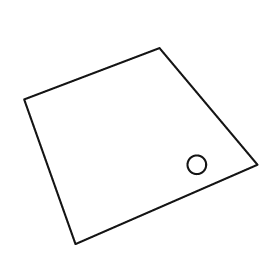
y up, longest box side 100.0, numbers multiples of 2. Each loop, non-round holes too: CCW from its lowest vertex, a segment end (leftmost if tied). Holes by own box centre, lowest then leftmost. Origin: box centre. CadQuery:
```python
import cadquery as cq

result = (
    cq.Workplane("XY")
    .moveTo(-28.0, -42.0)
    .lineTo(50.0, -8.0)
    .lineTo(8.0, 42.0)
    .lineTo(-50.0, 20.0)
    .close()
    .moveTo(24.0, -8.0)
    .circle(4.0)
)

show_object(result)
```